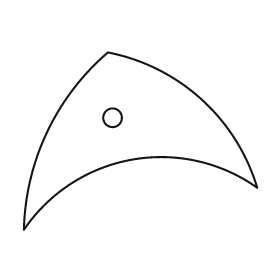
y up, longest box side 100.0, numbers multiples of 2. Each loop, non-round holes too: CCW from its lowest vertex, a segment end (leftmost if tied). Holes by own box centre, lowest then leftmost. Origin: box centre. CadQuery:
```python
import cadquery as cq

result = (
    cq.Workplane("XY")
    .moveTo(-50.0, -38.0)
    .threePointArc((-4.0, -8.0), (50.0, -20.0))
    .threePointArc((26.0, 18.0), (-14.0, 38.0))
    .threePointArc((-40.0, 4.0), (-50.0, -38.0))
    .close()
    .moveTo(-12.0, 10.0)
    .circle(4.0)
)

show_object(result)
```